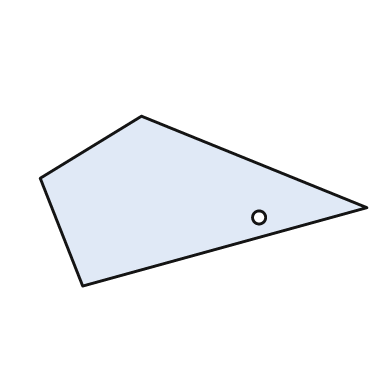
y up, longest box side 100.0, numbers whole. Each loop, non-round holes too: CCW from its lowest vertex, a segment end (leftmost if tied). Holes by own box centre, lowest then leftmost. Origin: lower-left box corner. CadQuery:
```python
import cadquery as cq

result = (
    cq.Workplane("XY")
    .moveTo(13.0, 0.0)
    .lineTo(100.0, 24.0)
    .lineTo(31.0, 52.0)
    .lineTo(0.0, 33.0)
    .close()
    .moveTo(67.0, 21.0)
    .circle(2.0)
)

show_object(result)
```